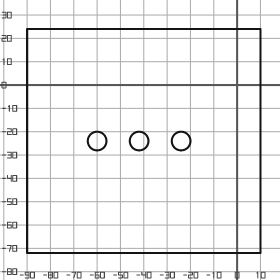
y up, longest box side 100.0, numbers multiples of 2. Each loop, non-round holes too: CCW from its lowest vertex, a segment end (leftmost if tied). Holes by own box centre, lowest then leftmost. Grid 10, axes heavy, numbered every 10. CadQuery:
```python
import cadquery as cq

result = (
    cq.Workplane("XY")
    .moveTo(-90.0, -72.0)
    .lineTo(10.0, -72.0)
    .lineTo(10.0, 24.0)
    .lineTo(-90.0, 24.0)
    .close()
    .moveTo(-60.0, -24.0)
    .circle(4.0)
    .moveTo(-42.0, -24.0)
    .circle(4.0)
    .moveTo(-24.0, -24.0)
    .circle(4.0)
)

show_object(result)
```